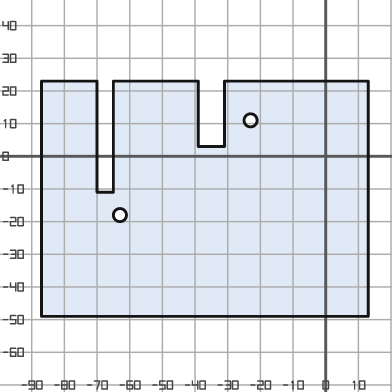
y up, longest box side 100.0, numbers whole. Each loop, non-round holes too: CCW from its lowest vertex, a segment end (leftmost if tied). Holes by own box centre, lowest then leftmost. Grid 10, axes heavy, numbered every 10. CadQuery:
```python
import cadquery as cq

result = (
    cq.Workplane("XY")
    .moveTo(-87.0, -49.0)
    .lineTo(13.0, -49.0)
    .lineTo(13.0, 23.0)
    .lineTo(-31.0, 23.0)
    .lineTo(-31.0, 3.0)
    .lineTo(-39.0, 3.0)
    .lineTo(-39.0, 23.0)
    .lineTo(-65.0, 23.0)
    .lineTo(-65.0, -11.0)
    .lineTo(-70.0, -11.0)
    .lineTo(-70.0, 23.0)
    .lineTo(-87.0, 23.0)
    .close()
    .moveTo(-63.0, -18.0)
    .circle(2.0)
    .moveTo(-23.0, 11.0)
    .circle(2.0)
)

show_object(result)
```